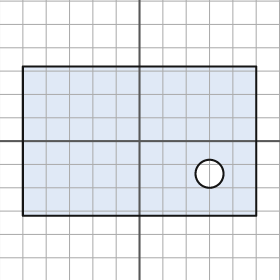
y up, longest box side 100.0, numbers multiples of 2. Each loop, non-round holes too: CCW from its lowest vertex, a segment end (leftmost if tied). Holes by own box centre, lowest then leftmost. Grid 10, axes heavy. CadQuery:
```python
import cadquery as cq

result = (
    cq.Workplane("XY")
    .moveTo(-50.0, -32.0)
    .lineTo(50.0, -32.0)
    .lineTo(50.0, 32.0)
    .lineTo(-50.0, 32.0)
    .close()
    .moveTo(30.0, -14.0)
    .circle(6.0)
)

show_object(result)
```